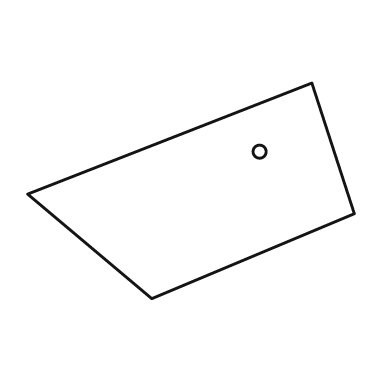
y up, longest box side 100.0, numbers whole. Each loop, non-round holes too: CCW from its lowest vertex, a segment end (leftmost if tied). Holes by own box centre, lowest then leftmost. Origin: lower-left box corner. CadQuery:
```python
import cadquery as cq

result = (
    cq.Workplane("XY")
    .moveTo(38.0, 0.0)
    .lineTo(100.0, 26.0)
    .lineTo(87.0, 66.0)
    .lineTo(0.0, 32.0)
    .close()
    .moveTo(71.0, 45.0)
    .circle(2.0)
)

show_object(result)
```